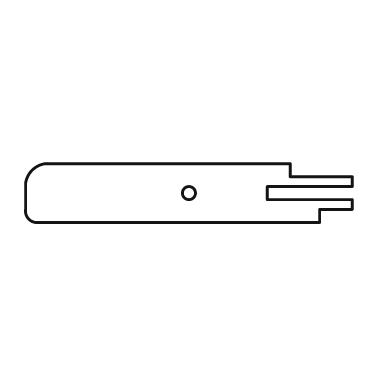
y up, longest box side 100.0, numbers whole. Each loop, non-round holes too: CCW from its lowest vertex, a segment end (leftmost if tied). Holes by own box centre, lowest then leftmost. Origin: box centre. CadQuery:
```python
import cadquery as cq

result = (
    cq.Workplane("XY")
    .moveTo(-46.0, -9.0)
    .lineTo(40.0, -9.0)
    .lineTo(40.0, -5.0)
    .lineTo(50.0, -5.0)
    .lineTo(50.0, -2.0)
    .lineTo(24.0, -2.0)
    .lineTo(24.0, 2.0)
    .lineTo(50.0, 2.0)
    .lineTo(50.0, 5.0)
    .lineTo(31.0, 5.0)
    .lineTo(31.0, 9.0)
    .lineTo(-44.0, 9.0)
    .threePointArc((-48.0, 7.0), (-50.0, 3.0))
    .lineTo(-50.0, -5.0)
    .threePointArc((-49.0, -8.0), (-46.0, -9.0))
    .close()
    .moveTo(0.0, 0.0)
    .circle(2.0)
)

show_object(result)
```